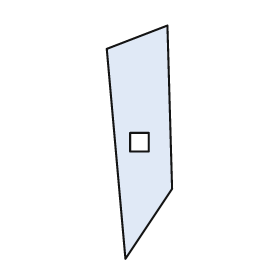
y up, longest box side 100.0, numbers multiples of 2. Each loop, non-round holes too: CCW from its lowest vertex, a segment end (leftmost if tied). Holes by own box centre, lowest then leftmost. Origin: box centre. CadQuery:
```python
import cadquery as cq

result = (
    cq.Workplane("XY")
    .moveTo(-6.0, -50.0)
    .lineTo(14.0, -20.0)
    .lineTo(12.0, 50.0)
    .lineTo(-14.0, 40.0)
    .close()
    .moveTo(-4.0, -4.0)
    .lineTo(4.0, -4.0)
    .lineTo(4.0, 4.0)
    .lineTo(-4.0, 4.0)
    .close()
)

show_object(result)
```